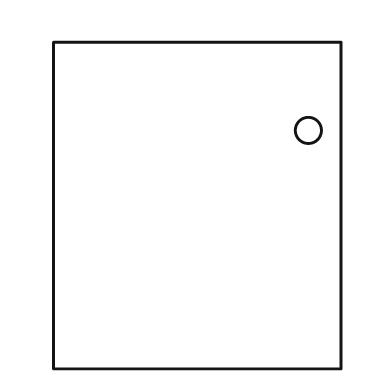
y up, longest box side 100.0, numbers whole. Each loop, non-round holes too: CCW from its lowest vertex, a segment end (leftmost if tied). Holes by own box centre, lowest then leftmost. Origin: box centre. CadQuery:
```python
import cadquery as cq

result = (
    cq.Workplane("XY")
    .moveTo(-44.0, -50.0)
    .lineTo(44.0, -50.0)
    .lineTo(44.0, 50.0)
    .lineTo(-44.0, 50.0)
    .close()
    .moveTo(34.0, 23.0)
    .circle(4.0)
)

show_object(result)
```